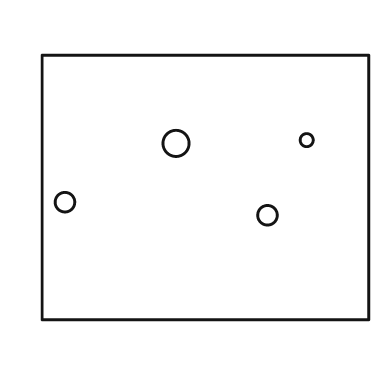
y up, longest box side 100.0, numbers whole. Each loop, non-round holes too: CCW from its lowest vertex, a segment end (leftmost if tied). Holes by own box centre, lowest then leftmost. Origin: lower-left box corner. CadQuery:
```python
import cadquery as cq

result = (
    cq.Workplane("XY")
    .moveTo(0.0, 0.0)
    .lineTo(100.0, 0.0)
    .lineTo(100.0, 81.0)
    .lineTo(0.0, 81.0)
    .close()
    .moveTo(69.0, 32.0)
    .circle(3.0)
    .moveTo(7.0, 36.0)
    .circle(3.0)
    .moveTo(41.0, 54.0)
    .circle(4.0)
    .moveTo(81.0, 55.0)
    .circle(2.0)
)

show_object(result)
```